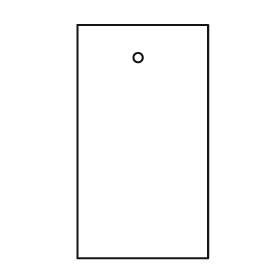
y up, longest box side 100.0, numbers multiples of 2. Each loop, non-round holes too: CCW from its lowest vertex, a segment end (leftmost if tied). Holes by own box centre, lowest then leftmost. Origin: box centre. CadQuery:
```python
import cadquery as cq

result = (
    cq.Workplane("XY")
    .moveTo(-28.0, -50.0)
    .lineTo(28.0, -50.0)
    .lineTo(28.0, 50.0)
    .lineTo(-28.0, 50.0)
    .close()
    .moveTo(-2.0, 36.0)
    .circle(2.0)
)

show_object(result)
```